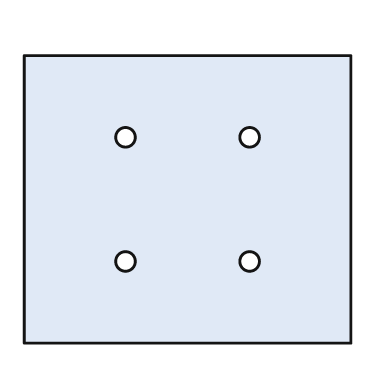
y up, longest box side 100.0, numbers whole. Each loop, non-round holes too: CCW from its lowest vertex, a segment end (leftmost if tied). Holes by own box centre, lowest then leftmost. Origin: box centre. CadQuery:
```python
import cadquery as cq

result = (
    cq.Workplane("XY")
    .moveTo(-50.0, -44.0)
    .lineTo(50.0, -44.0)
    .lineTo(50.0, 44.0)
    .lineTo(-50.0, 44.0)
    .close()
    .moveTo(-19.0, -19.0)
    .circle(3.0)
    .moveTo(19.0, -19.0)
    .circle(3.0)
    .moveTo(-19.0, 19.0)
    .circle(3.0)
    .moveTo(19.0, 19.0)
    .circle(3.0)
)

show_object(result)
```